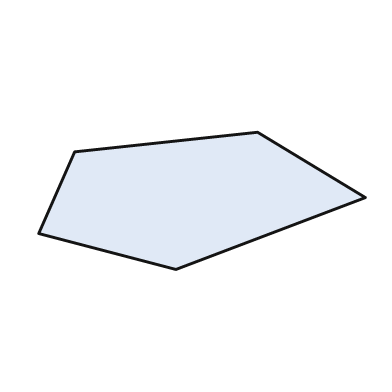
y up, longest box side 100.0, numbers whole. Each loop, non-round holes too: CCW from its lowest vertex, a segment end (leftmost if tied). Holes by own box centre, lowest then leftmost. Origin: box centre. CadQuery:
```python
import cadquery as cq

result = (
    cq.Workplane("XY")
    .moveTo(-8.0, -21.0)
    .lineTo(50.0, 1.0)
    .lineTo(17.0, 21.0)
    .lineTo(-39.0, 15.0)
    .lineTo(-50.0, -10.0)
    .close()
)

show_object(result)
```